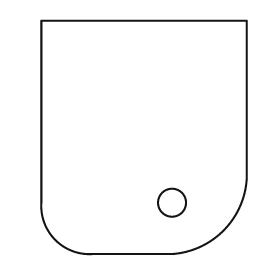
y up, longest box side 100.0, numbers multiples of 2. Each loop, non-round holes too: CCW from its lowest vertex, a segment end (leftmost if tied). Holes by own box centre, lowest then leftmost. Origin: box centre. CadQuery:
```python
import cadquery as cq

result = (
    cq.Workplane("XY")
    .moveTo(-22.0, -50.0)
    .lineTo(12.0, -50.0)
    .threePointArc((34.0, -40.0), (44.0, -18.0))
    .lineTo(44.0, 50.0)
    .lineTo(-44.0, 50.0)
    .lineTo(-44.0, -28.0)
    .threePointArc((-38.0, -44.0), (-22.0, -50.0))
    .close()
    .moveTo(12.0, -28.0)
    .circle(6.0)
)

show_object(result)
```